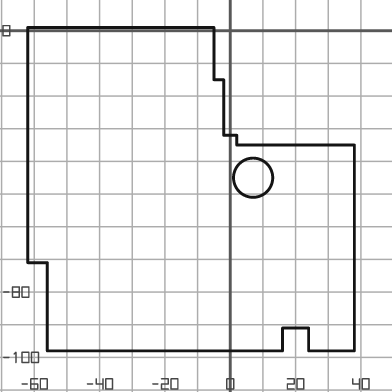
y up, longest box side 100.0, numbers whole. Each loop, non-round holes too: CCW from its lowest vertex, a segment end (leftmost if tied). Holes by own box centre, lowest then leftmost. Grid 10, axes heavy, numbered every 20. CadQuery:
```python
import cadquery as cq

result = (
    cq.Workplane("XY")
    .moveTo(-56.0, -98.0)
    .lineTo(16.0, -98.0)
    .lineTo(16.0, -91.0)
    .lineTo(24.0, -91.0)
    .lineTo(24.0, -98.0)
    .lineTo(38.0, -98.0)
    .lineTo(38.0, -35.0)
    .lineTo(2.0, -35.0)
    .lineTo(2.0, -32.0)
    .lineTo(-2.0, -32.0)
    .lineTo(-2.0, -15.0)
    .lineTo(-5.0, -15.0)
    .lineTo(-5.0, 1.0)
    .lineTo(-62.0, 1.0)
    .lineTo(-62.0, -71.0)
    .lineTo(-56.0, -71.0)
    .close()
    .moveTo(7.0, -45.0)
    .circle(6.0)
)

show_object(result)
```